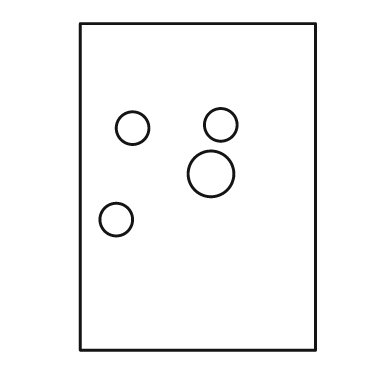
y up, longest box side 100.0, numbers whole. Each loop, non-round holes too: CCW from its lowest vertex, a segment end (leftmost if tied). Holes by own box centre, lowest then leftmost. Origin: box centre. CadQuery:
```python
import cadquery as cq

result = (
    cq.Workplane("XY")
    .moveTo(-36.0, -50.0)
    .lineTo(36.0, -50.0)
    .lineTo(36.0, 50.0)
    .lineTo(-36.0, 50.0)
    .close()
    .moveTo(-25.0, -10.0)
    .circle(5.0)
    .moveTo(4.0, 4.0)
    .circle(7.0)
    .moveTo(-20.0, 18.0)
    .circle(5.0)
    .moveTo(7.0, 19.0)
    .circle(5.0)
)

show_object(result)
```